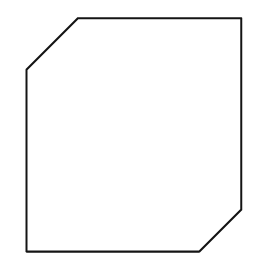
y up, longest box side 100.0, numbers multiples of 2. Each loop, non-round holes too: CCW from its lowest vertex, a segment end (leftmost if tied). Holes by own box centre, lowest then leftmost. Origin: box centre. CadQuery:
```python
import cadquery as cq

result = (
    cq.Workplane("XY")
    .moveTo(-46.0, -50.0)
    .lineTo(28.0, -50.0)
    .lineTo(46.0, -32.0)
    .lineTo(46.0, 50.0)
    .lineTo(-24.0, 50.0)
    .lineTo(-46.0, 28.0)
    .close()
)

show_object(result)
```